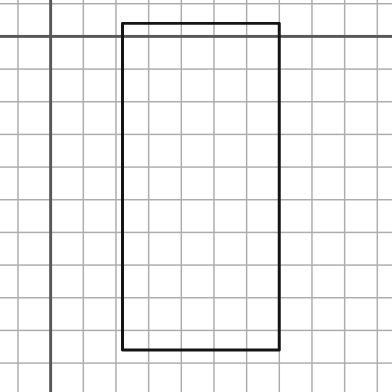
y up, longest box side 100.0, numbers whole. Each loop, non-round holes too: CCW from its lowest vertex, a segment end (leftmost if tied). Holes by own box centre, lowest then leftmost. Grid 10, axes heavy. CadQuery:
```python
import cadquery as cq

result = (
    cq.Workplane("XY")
    .moveTo(22.0, -96.0)
    .lineTo(70.0, -96.0)
    .lineTo(70.0, 4.0)
    .lineTo(22.0, 4.0)
    .close()
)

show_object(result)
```